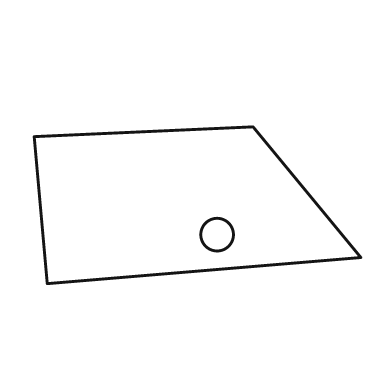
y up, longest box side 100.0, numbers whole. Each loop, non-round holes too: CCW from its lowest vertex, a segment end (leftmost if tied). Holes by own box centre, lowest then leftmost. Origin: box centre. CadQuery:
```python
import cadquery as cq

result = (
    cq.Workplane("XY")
    .moveTo(-46.0, -24.0)
    .lineTo(50.0, -16.0)
    .lineTo(17.0, 24.0)
    .lineTo(-50.0, 21.0)
    .close()
    .moveTo(6.0, -9.0)
    .circle(5.0)
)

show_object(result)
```